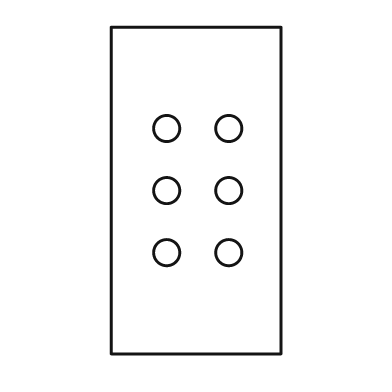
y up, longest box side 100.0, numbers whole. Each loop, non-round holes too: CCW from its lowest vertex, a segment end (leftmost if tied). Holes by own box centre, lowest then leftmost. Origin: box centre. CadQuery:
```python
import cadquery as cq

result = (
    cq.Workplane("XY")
    .moveTo(-26.0, -50.0)
    .lineTo(26.0, -50.0)
    .lineTo(26.0, 50.0)
    .lineTo(-26.0, 50.0)
    .close()
    .moveTo(-9.0, -19.0)
    .circle(4.0)
    .moveTo(10.0, -19.0)
    .circle(4.0)
    .moveTo(-9.0, 0.0)
    .circle(4.0)
    .moveTo(10.0, 0.0)
    .circle(4.0)
    .moveTo(-9.0, 19.0)
    .circle(4.0)
    .moveTo(10.0, 19.0)
    .circle(4.0)
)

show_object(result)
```